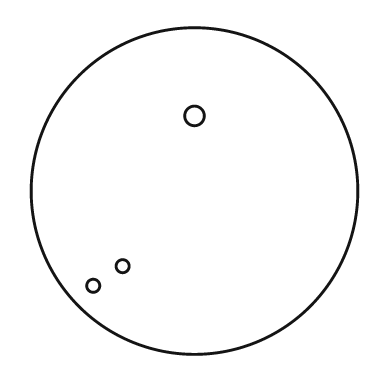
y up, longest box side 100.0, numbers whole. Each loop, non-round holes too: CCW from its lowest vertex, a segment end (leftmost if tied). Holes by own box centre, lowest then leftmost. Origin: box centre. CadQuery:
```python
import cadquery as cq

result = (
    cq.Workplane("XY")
    .moveTo(0.0, 0.0)
    .circle(50.0)
    .moveTo(-31.0, -29.0)
    .circle(2.0)
    .moveTo(-22.0, -23.0)
    .circle(2.0)
    .moveTo(0.0, 23.0)
    .circle(3.0)
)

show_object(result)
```